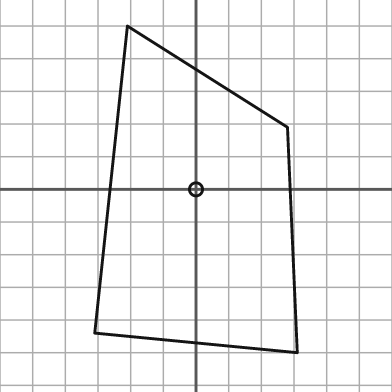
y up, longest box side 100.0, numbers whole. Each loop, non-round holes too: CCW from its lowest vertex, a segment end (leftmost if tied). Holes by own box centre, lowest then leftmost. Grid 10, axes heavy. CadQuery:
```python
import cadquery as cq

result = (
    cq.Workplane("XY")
    .moveTo(31.0, -50.0)
    .lineTo(28.0, 19.0)
    .lineTo(-21.0, 50.0)
    .lineTo(-31.0, -44.0)
    .close()
    .moveTo(0.0, 0.0)
    .circle(2.0)
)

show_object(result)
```